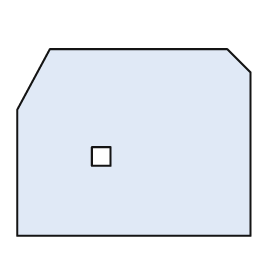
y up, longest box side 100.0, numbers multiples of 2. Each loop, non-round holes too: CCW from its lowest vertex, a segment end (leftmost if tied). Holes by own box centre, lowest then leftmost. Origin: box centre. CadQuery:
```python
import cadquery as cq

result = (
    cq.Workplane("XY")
    .moveTo(-50.0, -40.0)
    .lineTo(50.0, -40.0)
    .lineTo(50.0, 30.0)
    .lineTo(40.0, 40.0)
    .lineTo(-36.0, 40.0)
    .lineTo(-50.0, 14.0)
    .close()
    .moveTo(-18.0, -10.0)
    .lineTo(-10.0, -10.0)
    .lineTo(-10.0, -2.0)
    .lineTo(-18.0, -2.0)
    .close()
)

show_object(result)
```